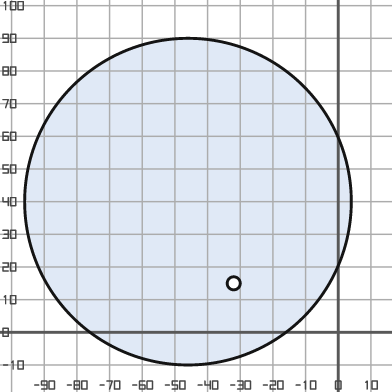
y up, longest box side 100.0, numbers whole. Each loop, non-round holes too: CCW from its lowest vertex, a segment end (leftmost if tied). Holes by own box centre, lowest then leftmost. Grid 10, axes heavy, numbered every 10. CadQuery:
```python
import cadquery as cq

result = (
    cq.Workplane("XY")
    .moveTo(-46.0, 40.0)
    .circle(50.0)
    .moveTo(-32.0, 15.0)
    .circle(2.0)
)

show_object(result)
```